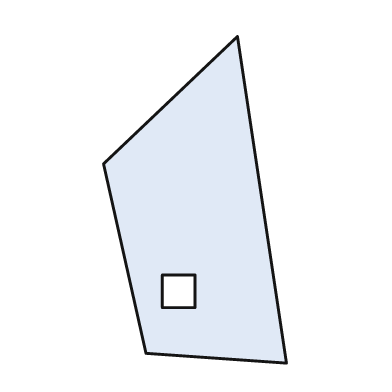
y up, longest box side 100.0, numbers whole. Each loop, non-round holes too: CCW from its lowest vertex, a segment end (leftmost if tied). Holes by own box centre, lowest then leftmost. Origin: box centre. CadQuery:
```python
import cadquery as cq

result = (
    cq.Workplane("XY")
    .moveTo(28.0, -50.0)
    .lineTo(13.0, 50.0)
    .lineTo(-28.0, 11.0)
    .lineTo(-15.0, -47.0)
    .close()
    .moveTo(-10.0, -33.0)
    .lineTo(0.0, -33.0)
    .lineTo(0.0, -23.0)
    .lineTo(-10.0, -23.0)
    .close()
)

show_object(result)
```